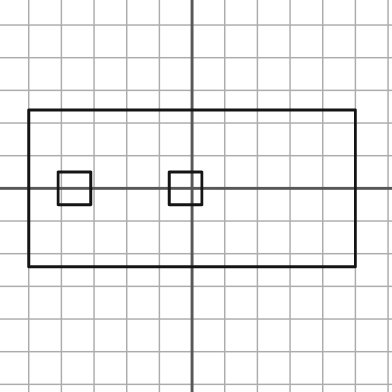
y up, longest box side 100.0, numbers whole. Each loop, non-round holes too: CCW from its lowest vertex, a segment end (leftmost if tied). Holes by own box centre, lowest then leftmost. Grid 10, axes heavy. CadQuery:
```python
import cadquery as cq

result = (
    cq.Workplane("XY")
    .moveTo(-50.0, -24.0)
    .lineTo(50.0, -24.0)
    .lineTo(50.0, 24.0)
    .lineTo(-50.0, 24.0)
    .close()
    .moveTo(-41.0, -5.0)
    .lineTo(-31.0, -5.0)
    .lineTo(-31.0, 5.0)
    .lineTo(-41.0, 5.0)
    .close()
    .moveTo(-7.0, -5.0)
    .lineTo(3.0, -5.0)
    .lineTo(3.0, 5.0)
    .lineTo(-7.0, 5.0)
    .close()
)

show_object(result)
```